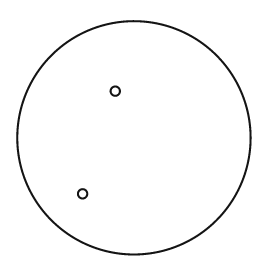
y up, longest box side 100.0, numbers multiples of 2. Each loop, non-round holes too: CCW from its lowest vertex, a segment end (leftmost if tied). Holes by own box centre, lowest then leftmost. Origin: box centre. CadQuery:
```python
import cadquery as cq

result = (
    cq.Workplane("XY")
    .moveTo(0.0, 0.0)
    .circle(50.0)
    .moveTo(-22.0, -24.0)
    .circle(2.0)
    .moveTo(-8.0, 20.0)
    .circle(2.0)
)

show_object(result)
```